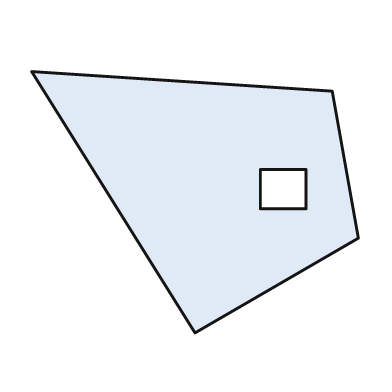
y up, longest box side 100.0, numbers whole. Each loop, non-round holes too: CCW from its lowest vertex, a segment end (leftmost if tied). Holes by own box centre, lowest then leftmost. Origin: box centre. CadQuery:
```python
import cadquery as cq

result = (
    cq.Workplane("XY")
    .moveTo(0.0, -40.0)
    .lineTo(50.0, -11.0)
    .lineTo(42.0, 34.0)
    .lineTo(-50.0, 40.0)
    .close()
    .moveTo(20.0, -2.0)
    .lineTo(34.0, -2.0)
    .lineTo(34.0, 10.0)
    .lineTo(20.0, 10.0)
    .close()
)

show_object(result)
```